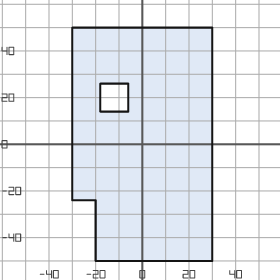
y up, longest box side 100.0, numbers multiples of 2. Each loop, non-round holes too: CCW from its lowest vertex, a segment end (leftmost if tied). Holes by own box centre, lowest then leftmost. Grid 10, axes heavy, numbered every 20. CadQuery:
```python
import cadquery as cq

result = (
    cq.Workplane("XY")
    .moveTo(-20.0, -50.0)
    .lineTo(30.0, -50.0)
    .lineTo(30.0, 50.0)
    .lineTo(-30.0, 50.0)
    .lineTo(-30.0, -24.0)
    .lineTo(-20.0, -24.0)
    .close()
    .moveTo(-18.0, 14.0)
    .lineTo(-6.0, 14.0)
    .lineTo(-6.0, 26.0)
    .lineTo(-18.0, 26.0)
    .close()
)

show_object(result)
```